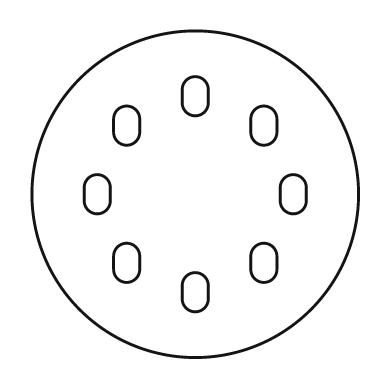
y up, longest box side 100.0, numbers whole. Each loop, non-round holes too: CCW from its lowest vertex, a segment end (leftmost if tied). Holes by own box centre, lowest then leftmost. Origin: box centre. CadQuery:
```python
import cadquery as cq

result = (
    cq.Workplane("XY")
    .moveTo(0.0, 0.0)
    .circle(50.0)
    .moveTo(-4.0, -32.0)
    .threePointArc((0.0, -36.0), (4.0, -32.0))
    .lineTo(4.0, -28.0)
    .threePointArc((0.0, -24.0), (-4.0, -28.0))
    .close()
    .moveTo(-25.0, -23.0)
    .threePointArc((-21.0, -27.0), (-17.0, -23.0))
    .lineTo(-17.0, -19.0)
    .threePointArc((-21.0, -15.0), (-25.0, -19.0))
    .close()
    .moveTo(17.0, -23.0)
    .threePointArc((21.0, -27.0), (25.0, -23.0))
    .lineTo(25.0, -19.0)
    .threePointArc((21.0, -15.0), (17.0, -19.0))
    .close()
    .moveTo(-34.0, -2.0)
    .threePointArc((-30.0, -6.0), (-26.0, -2.0))
    .lineTo(-26.0, 2.0)
    .threePointArc((-30.0, 6.0), (-34.0, 2.0))
    .close()
    .moveTo(26.0, -2.0)
    .threePointArc((30.0, -6.0), (34.0, -2.0))
    .lineTo(34.0, 2.0)
    .threePointArc((30.0, 6.0), (26.0, 2.0))
    .close()
    .moveTo(-25.0, 19.0)
    .threePointArc((-21.0, 15.0), (-17.0, 19.0))
    .lineTo(-17.0, 23.0)
    .threePointArc((-21.0, 27.0), (-25.0, 23.0))
    .close()
    .moveTo(17.0, 19.0)
    .threePointArc((21.0, 15.0), (25.0, 19.0))
    .lineTo(25.0, 23.0)
    .threePointArc((21.0, 27.0), (17.0, 23.0))
    .close()
    .moveTo(-4.0, 28.0)
    .threePointArc((0.0, 24.0), (4.0, 28.0))
    .lineTo(4.0, 32.0)
    .threePointArc((0.0, 36.0), (-4.0, 32.0))
    .close()
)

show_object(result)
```